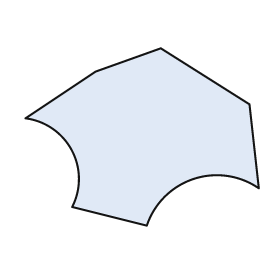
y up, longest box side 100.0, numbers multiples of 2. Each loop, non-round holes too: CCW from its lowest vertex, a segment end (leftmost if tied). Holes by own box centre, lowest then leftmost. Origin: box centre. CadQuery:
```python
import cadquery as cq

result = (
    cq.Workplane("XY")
    .moveTo(2.0, -38.0)
    .threePointArc((22.0, -18.0), (50.0, -22.0))
    .lineTo(46.0, 14.0)
    .lineTo(8.0, 38.0)
    .lineTo(-20.0, 28.0)
    .lineTo(-50.0, 8.0)
    .threePointArc((-30.0, -6.0), (-30.0, -30.0))
    .close()
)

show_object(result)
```